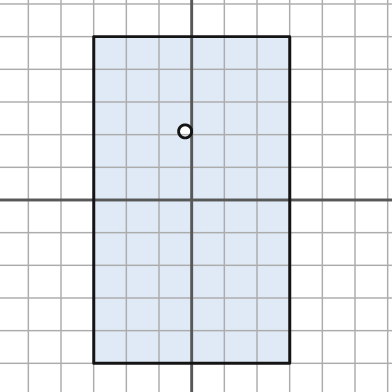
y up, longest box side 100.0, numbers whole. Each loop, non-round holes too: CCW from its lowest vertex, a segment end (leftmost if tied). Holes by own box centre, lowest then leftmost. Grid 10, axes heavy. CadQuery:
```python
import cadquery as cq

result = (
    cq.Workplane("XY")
    .moveTo(-30.0, -50.0)
    .lineTo(30.0, -50.0)
    .lineTo(30.0, 50.0)
    .lineTo(-30.0, 50.0)
    .close()
    .moveTo(-2.0, 21.0)
    .circle(2.0)
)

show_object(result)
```